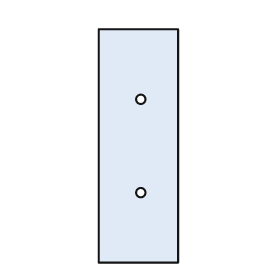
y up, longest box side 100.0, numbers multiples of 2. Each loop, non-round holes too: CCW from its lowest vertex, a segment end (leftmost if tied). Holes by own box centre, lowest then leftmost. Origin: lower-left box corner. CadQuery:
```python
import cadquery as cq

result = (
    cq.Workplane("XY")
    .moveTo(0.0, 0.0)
    .lineTo(34.0, 0.0)
    .lineTo(34.0, 100.0)
    .lineTo(0.0, 100.0)
    .close()
    .moveTo(18.0, 30.0)
    .circle(2.0)
    .moveTo(18.0, 70.0)
    .circle(2.0)
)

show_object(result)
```